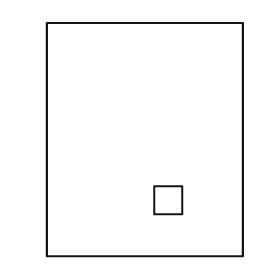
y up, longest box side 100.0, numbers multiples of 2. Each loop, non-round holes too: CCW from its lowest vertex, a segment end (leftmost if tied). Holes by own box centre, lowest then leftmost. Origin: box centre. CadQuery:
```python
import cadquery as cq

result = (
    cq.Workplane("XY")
    .moveTo(-42.0, -50.0)
    .lineTo(42.0, -50.0)
    .lineTo(42.0, 50.0)
    .lineTo(-42.0, 50.0)
    .close()
    .moveTo(4.0, -32.0)
    .lineTo(16.0, -32.0)
    .lineTo(16.0, -20.0)
    .lineTo(4.0, -20.0)
    .close()
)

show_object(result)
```